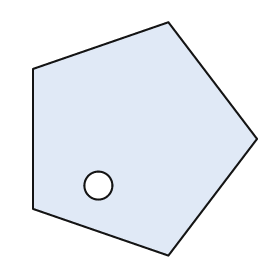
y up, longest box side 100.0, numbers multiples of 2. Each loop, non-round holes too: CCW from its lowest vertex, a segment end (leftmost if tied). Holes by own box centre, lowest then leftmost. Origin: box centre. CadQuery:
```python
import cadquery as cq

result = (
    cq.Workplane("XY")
    .moveTo(10.0, -50.0)
    .lineTo(48.0, 0.0)
    .lineTo(10.0, 50.0)
    .lineTo(-48.0, 30.0)
    .lineTo(-48.0, -30.0)
    .close()
    .moveTo(-20.0, -20.0)
    .circle(6.0)
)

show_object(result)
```